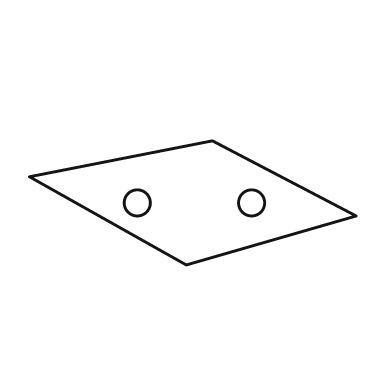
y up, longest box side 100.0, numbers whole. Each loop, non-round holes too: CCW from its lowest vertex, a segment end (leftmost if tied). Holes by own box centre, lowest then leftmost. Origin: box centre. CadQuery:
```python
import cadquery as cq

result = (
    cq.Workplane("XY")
    .moveTo(-2.0, -19.0)
    .lineTo(50.0, -4.0)
    .lineTo(6.0, 19.0)
    .lineTo(-50.0, 8.0)
    .close()
    .moveTo(-17.0, 0.0)
    .circle(4.0)
    .moveTo(18.0, 0.0)
    .circle(4.0)
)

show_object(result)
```